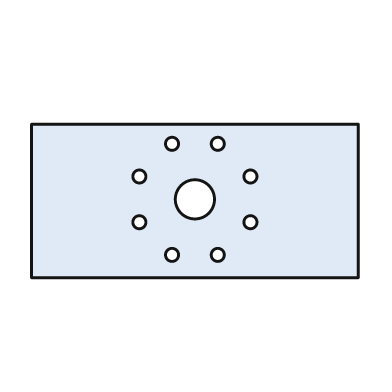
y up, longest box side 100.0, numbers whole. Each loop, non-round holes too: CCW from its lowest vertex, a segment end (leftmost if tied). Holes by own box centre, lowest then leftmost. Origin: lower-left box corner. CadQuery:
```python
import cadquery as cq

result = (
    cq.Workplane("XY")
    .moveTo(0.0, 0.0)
    .lineTo(100.0, 0.0)
    .lineTo(100.0, 47.0)
    .lineTo(0.0, 47.0)
    .close()
    .moveTo(43.0, 7.0)
    .circle(2.0)
    .moveTo(57.0, 7.0)
    .circle(2.0)
    .moveTo(33.0, 17.0)
    .circle(2.0)
    .moveTo(67.0, 17.0)
    .circle(2.0)
    .moveTo(50.0, 24.0)
    .circle(6.0)
    .moveTo(33.0, 31.0)
    .circle(2.0)
    .moveTo(67.0, 31.0)
    .circle(2.0)
    .moveTo(43.0, 41.0)
    .circle(2.0)
    .moveTo(57.0, 41.0)
    .circle(2.0)
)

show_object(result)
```